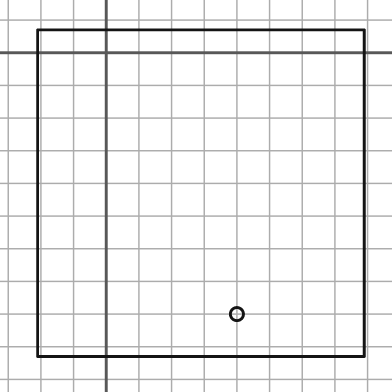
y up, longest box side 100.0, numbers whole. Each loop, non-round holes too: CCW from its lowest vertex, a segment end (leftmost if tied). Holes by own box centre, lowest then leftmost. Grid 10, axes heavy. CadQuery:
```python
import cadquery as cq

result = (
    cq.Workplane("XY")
    .moveTo(-21.0, -93.0)
    .lineTo(79.0, -93.0)
    .lineTo(79.0, 7.0)
    .lineTo(-21.0, 7.0)
    .close()
    .moveTo(40.0, -80.0)
    .circle(2.0)
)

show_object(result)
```